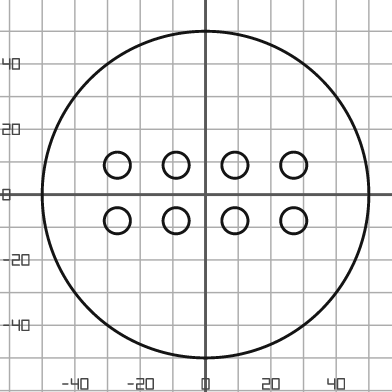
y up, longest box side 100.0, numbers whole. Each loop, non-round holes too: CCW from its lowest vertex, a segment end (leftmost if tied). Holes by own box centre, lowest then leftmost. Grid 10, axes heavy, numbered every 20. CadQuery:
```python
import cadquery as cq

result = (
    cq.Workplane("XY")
    .moveTo(0.0, 0.0)
    .circle(50.0)
    .moveTo(-27.0, -8.0)
    .circle(4.0)
    .moveTo(-9.0, -8.0)
    .circle(4.0)
    .moveTo(9.0, -8.0)
    .circle(4.0)
    .moveTo(27.0, -8.0)
    .circle(4.0)
    .moveTo(-27.0, 9.0)
    .circle(4.0)
    .moveTo(-9.0, 9.0)
    .circle(4.0)
    .moveTo(9.0, 9.0)
    .circle(4.0)
    .moveTo(27.0, 9.0)
    .circle(4.0)
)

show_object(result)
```